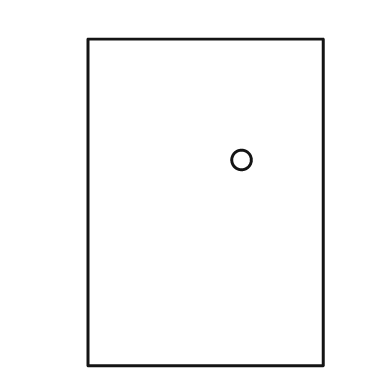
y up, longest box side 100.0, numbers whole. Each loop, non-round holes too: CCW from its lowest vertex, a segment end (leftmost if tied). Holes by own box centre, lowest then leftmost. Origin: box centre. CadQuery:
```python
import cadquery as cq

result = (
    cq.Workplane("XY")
    .moveTo(-36.0, -50.0)
    .lineTo(36.0, -50.0)
    .lineTo(36.0, 50.0)
    .lineTo(-36.0, 50.0)
    .close()
    .moveTo(11.0, 13.0)
    .circle(3.0)
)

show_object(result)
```